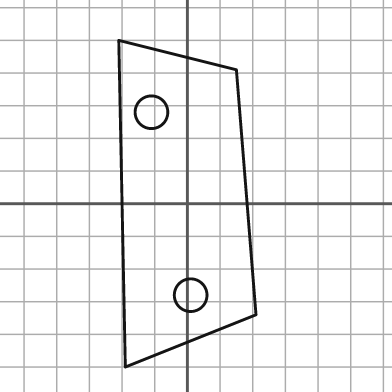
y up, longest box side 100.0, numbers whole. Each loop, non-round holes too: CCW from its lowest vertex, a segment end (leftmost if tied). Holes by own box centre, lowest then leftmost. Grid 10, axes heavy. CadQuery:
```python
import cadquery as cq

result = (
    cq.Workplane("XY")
    .moveTo(-19.0, -50.0)
    .lineTo(21.0, -34.0)
    .lineTo(15.0, 41.0)
    .lineTo(-21.0, 50.0)
    .close()
    .moveTo(1.0, -28.0)
    .circle(5.0)
    .moveTo(-11.0, 28.0)
    .circle(5.0)
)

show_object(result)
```